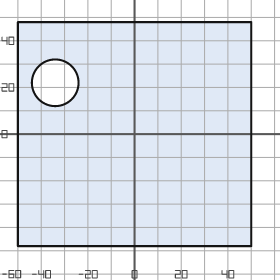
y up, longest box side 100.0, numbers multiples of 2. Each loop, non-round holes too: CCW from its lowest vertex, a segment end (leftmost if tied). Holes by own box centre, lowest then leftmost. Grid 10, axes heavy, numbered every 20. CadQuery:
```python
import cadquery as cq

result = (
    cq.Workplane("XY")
    .moveTo(-50.0, -48.0)
    .lineTo(50.0, -48.0)
    .lineTo(50.0, 48.0)
    .lineTo(-50.0, 48.0)
    .close()
    .moveTo(-34.0, 22.0)
    .circle(10.0)
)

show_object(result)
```